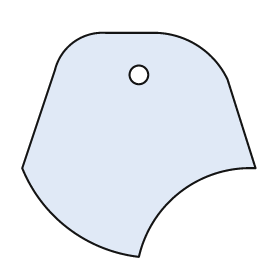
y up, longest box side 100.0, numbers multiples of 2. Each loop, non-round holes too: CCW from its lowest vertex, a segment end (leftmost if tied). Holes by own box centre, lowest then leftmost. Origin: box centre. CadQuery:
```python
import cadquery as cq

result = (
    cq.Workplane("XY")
    .moveTo(0.0, -48.0)
    .threePointArc((18.0, -20.0), (50.0, -10.0))
    .lineTo(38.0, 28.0)
    .threePointArc((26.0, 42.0), (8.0, 48.0))
    .lineTo(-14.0, 48.0)
    .threePointArc((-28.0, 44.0), (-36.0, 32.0))
    .lineTo(-50.0, -10.0)
    .threePointArc((-30.0, -36.0), (0.0, -48.0))
    .close()
    .moveTo(0.0, 30.0)
    .circle(4.0)
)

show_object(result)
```